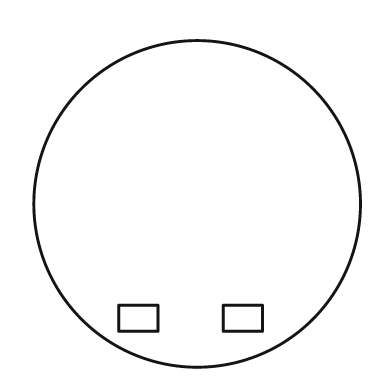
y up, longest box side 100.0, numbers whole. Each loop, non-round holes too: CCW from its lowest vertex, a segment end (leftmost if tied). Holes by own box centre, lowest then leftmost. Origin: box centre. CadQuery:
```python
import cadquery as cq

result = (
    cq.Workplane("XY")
    .moveTo(0.0, 0.0)
    .circle(50.0)
    .moveTo(-24.0, -39.0)
    .lineTo(-12.0, -39.0)
    .lineTo(-12.0, -31.0)
    .lineTo(-24.0, -31.0)
    .close()
    .moveTo(8.0, -39.0)
    .lineTo(20.0, -39.0)
    .lineTo(20.0, -31.0)
    .lineTo(8.0, -31.0)
    .close()
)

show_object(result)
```